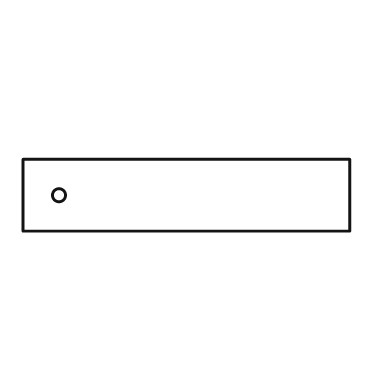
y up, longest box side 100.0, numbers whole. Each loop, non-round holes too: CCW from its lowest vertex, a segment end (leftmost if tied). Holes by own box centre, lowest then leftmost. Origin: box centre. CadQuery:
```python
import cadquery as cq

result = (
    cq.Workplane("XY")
    .moveTo(-50.0, -11.0)
    .lineTo(50.0, -11.0)
    .lineTo(50.0, 11.0)
    .lineTo(-50.0, 11.0)
    .close()
    .moveTo(-39.0, 0.0)
    .circle(2.0)
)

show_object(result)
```